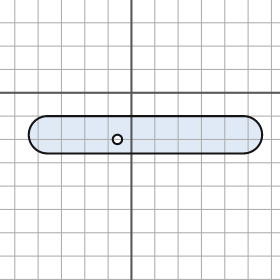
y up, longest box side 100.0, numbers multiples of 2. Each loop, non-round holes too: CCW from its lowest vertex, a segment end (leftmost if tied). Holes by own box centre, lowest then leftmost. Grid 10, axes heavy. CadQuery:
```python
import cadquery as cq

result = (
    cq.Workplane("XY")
    .moveTo(-36.0, -26.0)
    .lineTo(48.0, -26.0)
    .threePointArc((56.0, -18.0), (48.0, -10.0))
    .lineTo(-36.0, -10.0)
    .threePointArc((-44.0, -18.0), (-36.0, -26.0))
    .close()
    .moveTo(-6.0, -20.0)
    .circle(2.0)
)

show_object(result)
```